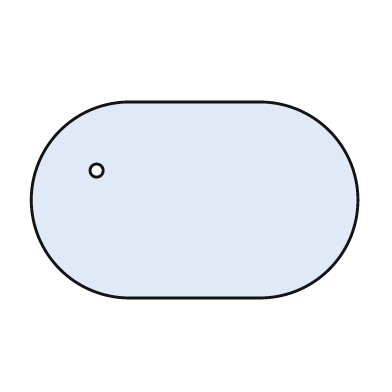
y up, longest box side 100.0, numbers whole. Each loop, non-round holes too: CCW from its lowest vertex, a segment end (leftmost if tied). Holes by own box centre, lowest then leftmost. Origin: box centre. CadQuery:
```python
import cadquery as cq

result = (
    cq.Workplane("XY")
    .moveTo(-20.0, -30.0)
    .lineTo(20.0, -30.0)
    .threePointArc((50.0, 0.0), (20.0, 30.0))
    .lineTo(-20.0, 30.0)
    .threePointArc((-50.0, 0.0), (-20.0, -30.0))
    .close()
    .moveTo(-30.0, 9.0)
    .circle(2.0)
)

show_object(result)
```